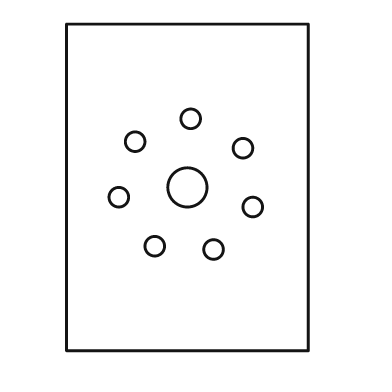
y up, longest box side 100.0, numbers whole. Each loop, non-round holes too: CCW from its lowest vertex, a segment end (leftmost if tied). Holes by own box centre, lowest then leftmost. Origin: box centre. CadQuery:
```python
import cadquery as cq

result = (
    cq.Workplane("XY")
    .moveTo(-37.0, -50.0)
    .lineTo(37.0, -50.0)
    .lineTo(37.0, 50.0)
    .lineTo(-37.0, 50.0)
    .close()
    .moveTo(8.0, -19.0)
    .circle(3.0)
    .moveTo(-10.0, -18.0)
    .circle(3.0)
    .moveTo(20.0, -6.0)
    .circle(3.0)
    .moveTo(-21.0, -3.0)
    .circle(3.0)
    .moveTo(0.0, 0.0)
    .circle(6.0)
    .moveTo(17.0, 12.0)
    .circle(3.0)
    .moveTo(-16.0, 14.0)
    .circle(3.0)
    .moveTo(1.0, 21.0)
    .circle(3.0)
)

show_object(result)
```